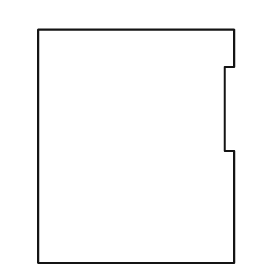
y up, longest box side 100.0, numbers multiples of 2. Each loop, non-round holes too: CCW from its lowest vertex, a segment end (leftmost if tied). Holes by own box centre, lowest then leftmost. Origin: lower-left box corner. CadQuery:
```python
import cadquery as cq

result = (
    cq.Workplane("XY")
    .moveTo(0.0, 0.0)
    .lineTo(84.0, 0.0)
    .lineTo(84.0, 48.0)
    .lineTo(80.0, 48.0)
    .lineTo(80.0, 84.0)
    .lineTo(84.0, 84.0)
    .lineTo(84.0, 100.0)
    .lineTo(0.0, 100.0)
    .close()
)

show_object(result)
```